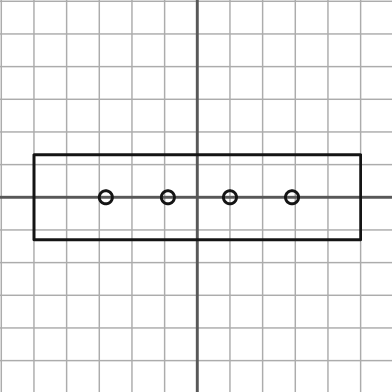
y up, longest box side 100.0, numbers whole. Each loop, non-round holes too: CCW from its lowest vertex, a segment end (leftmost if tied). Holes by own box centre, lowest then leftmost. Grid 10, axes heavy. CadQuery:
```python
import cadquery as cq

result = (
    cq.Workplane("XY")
    .moveTo(-50.0, -13.0)
    .lineTo(50.0, -13.0)
    .lineTo(50.0, 13.0)
    .lineTo(-50.0, 13.0)
    .close()
    .moveTo(-28.0, 0.0)
    .circle(2.0)
    .moveTo(-9.0, 0.0)
    .circle(2.0)
    .moveTo(10.0, 0.0)
    .circle(2.0)
    .moveTo(29.0, 0.0)
    .circle(2.0)
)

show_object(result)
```